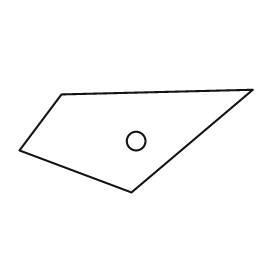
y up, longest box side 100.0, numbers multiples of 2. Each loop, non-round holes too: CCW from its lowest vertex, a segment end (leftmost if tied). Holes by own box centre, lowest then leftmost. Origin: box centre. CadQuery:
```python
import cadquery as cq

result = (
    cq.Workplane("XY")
    .moveTo(-2.0, -22.0)
    .lineTo(50.0, 22.0)
    .lineTo(-32.0, 20.0)
    .lineTo(-50.0, -4.0)
    .close()
    .moveTo(0.0, 0.0)
    .circle(4.0)
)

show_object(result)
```